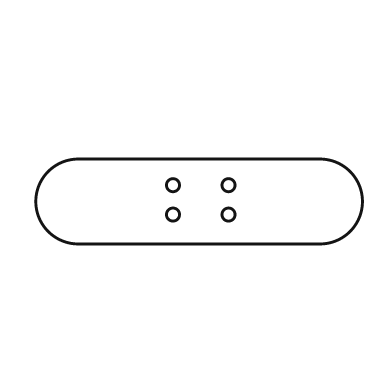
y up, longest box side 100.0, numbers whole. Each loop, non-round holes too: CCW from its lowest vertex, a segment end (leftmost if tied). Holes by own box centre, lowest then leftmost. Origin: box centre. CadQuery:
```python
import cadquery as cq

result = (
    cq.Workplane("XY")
    .moveTo(-37.0, -13.0)
    .lineTo(37.0, -13.0)
    .threePointArc((50.0, 0.0), (37.0, 13.0))
    .lineTo(-37.0, 13.0)
    .threePointArc((-50.0, 0.0), (-37.0, -13.0))
    .close()
    .moveTo(-8.0, -4.0)
    .circle(2.0)
    .moveTo(9.0, -4.0)
    .circle(2.0)
    .moveTo(-8.0, 5.0)
    .circle(2.0)
    .moveTo(9.0, 5.0)
    .circle(2.0)
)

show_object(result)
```